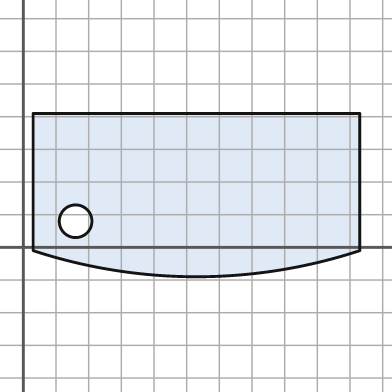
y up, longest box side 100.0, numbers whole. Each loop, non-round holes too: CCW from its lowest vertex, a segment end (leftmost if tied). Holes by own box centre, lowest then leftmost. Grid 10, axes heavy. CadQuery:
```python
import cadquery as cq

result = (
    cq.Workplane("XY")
    .moveTo(3.0, -1.0)
    .threePointArc((53.0, -9.0), (103.0, -1.0))
    .lineTo(103.0, 41.0)
    .lineTo(3.0, 41.0)
    .close()
    .moveTo(16.0, 8.0)
    .circle(5.0)
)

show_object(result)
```